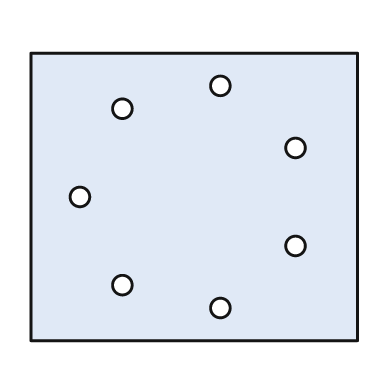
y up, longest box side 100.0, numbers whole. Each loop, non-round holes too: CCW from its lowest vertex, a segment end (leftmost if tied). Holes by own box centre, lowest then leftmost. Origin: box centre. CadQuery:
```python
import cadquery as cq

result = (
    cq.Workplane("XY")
    .moveTo(-50.0, -44.0)
    .lineTo(50.0, -44.0)
    .lineTo(50.0, 44.0)
    .lineTo(-50.0, 44.0)
    .close()
    .moveTo(8.0, -34.0)
    .circle(3.0)
    .moveTo(-22.0, -27.0)
    .circle(3.0)
    .moveTo(31.0, -15.0)
    .circle(3.0)
    .moveTo(-35.0, 0.0)
    .circle(3.0)
    .moveTo(31.0, 15.0)
    .circle(3.0)
    .moveTo(-22.0, 27.0)
    .circle(3.0)
    .moveTo(8.0, 34.0)
    .circle(3.0)
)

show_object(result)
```